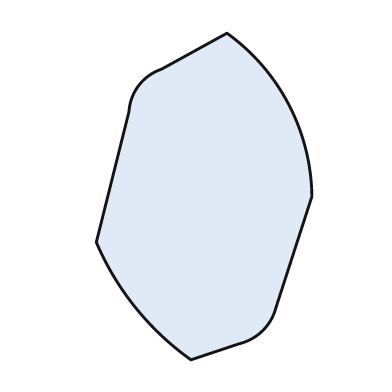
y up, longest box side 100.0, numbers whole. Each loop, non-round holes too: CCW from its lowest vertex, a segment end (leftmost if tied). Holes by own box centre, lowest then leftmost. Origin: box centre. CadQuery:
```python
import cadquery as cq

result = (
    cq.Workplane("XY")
    .moveTo(-4.0, -50.0)
    .lineTo(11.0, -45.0)
    .threePointArc((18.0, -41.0), (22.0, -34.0))
    .lineTo(33.0, 0.0)
    .threePointArc((26.0, 28.0), (7.0, 50.0))
    .lineTo(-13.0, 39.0)
    .threePointArc((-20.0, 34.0), (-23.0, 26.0))
    .lineTo(-33.0, -14.0)
    .threePointArc((-21.0, -34.0), (-4.0, -50.0))
    .close()
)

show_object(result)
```